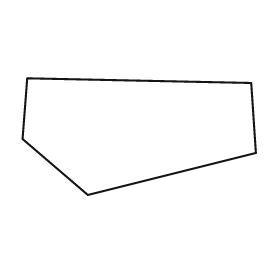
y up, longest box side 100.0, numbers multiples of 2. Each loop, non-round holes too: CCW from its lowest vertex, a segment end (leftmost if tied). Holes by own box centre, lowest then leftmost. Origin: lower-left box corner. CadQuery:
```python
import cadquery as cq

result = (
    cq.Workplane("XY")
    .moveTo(28.0, 0.0)
    .lineTo(100.0, 18.0)
    .lineTo(98.0, 48.0)
    .lineTo(2.0, 50.0)
    .lineTo(0.0, 24.0)
    .close()
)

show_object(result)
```